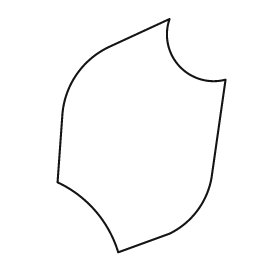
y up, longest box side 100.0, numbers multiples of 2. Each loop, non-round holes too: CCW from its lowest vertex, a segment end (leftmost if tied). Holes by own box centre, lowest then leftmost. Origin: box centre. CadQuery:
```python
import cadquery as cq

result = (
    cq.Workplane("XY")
    .moveTo(-10.0, -50.0)
    .lineTo(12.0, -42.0)
    .threePointArc((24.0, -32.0), (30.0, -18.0))
    .lineTo(36.0, 24.0)
    .threePointArc((16.0, 30.0), (12.0, 50.0))
    .lineTo(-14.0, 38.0)
    .threePointArc((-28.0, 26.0), (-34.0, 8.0))
    .lineTo(-36.0, -20.0)
    .threePointArc((-20.0, -32.0), (-10.0, -50.0))
    .close()
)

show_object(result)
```